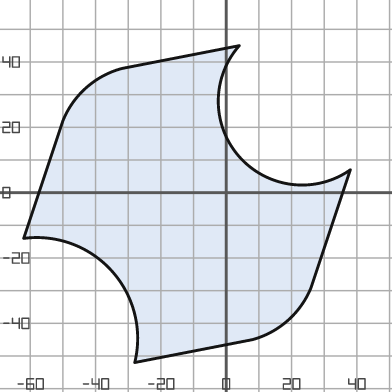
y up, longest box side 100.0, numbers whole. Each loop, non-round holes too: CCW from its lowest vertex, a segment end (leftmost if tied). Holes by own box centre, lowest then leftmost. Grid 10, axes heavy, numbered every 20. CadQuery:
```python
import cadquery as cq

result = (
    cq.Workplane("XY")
    .moveTo(-28.0, -52.0)
    .lineTo(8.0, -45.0)
    .threePointArc((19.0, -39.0), (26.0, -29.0))
    .lineTo(38.0, 7.0)
    .threePointArc((4.0, 11.0), (4.0, 45.0))
    .lineTo(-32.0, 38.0)
    .threePointArc((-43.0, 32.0), (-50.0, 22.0))
    .lineTo(-62.0, -14.0)
    .threePointArc((-35.0, -24.0), (-28.0, -52.0))
    .close()
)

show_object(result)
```